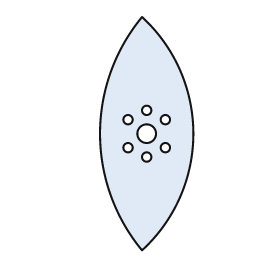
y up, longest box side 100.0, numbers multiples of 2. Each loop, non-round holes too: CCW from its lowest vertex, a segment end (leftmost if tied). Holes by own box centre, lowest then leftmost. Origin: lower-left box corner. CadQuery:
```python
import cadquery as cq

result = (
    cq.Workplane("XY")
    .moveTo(18.0, 0.0)
    .threePointArc((40.0, 50.0), (18.0, 100.0))
    .threePointArc((0.0, 50.0), (18.0, 0.0))
    .close()
    .moveTo(20.0, 40.0)
    .circle(2.0)
    .moveTo(12.0, 44.0)
    .circle(2.0)
    .moveTo(28.0, 44.0)
    .circle(2.0)
    .moveTo(20.0, 50.0)
    .circle(4.0)
    .moveTo(12.0, 56.0)
    .circle(2.0)
    .moveTo(28.0, 56.0)
    .circle(2.0)
    .moveTo(20.0, 60.0)
    .circle(2.0)
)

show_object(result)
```